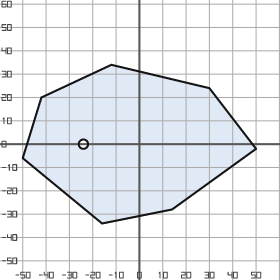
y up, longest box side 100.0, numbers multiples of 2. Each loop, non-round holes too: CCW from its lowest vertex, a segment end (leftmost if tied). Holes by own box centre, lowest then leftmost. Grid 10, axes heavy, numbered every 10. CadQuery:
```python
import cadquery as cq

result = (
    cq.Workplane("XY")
    .moveTo(-16.0, -34.0)
    .lineTo(14.0, -28.0)
    .lineTo(50.0, -2.0)
    .lineTo(30.0, 24.0)
    .lineTo(-12.0, 34.0)
    .lineTo(-42.0, 20.0)
    .lineTo(-50.0, -6.0)
    .close()
    .moveTo(-24.0, 0.0)
    .circle(2.0)
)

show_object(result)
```